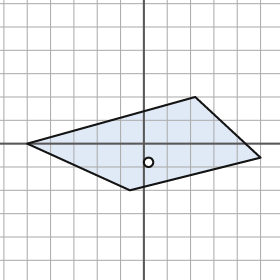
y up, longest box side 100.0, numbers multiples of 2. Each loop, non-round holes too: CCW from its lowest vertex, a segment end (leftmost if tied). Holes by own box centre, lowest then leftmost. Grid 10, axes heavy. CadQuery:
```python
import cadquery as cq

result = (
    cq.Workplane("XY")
    .moveTo(-6.0, -20.0)
    .lineTo(50.0, -6.0)
    .lineTo(22.0, 20.0)
    .lineTo(-50.0, 0.0)
    .close()
    .moveTo(2.0, -8.0)
    .circle(2.0)
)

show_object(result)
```